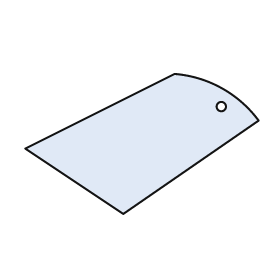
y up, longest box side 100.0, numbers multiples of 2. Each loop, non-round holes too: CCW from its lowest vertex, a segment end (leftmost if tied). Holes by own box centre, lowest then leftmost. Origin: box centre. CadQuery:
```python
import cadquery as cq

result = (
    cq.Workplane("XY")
    .moveTo(-8.0, -30.0)
    .lineTo(50.0, 10.0)
    .threePointArc((34.0, 24.0), (14.0, 30.0))
    .lineTo(-50.0, -2.0)
    .close()
    .moveTo(34.0, 16.0)
    .circle(2.0)
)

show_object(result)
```